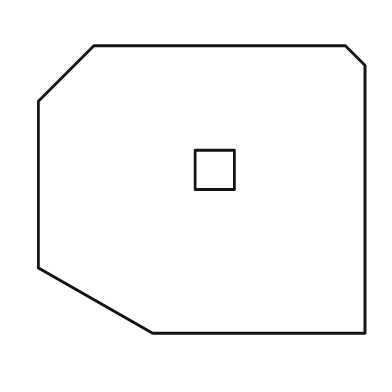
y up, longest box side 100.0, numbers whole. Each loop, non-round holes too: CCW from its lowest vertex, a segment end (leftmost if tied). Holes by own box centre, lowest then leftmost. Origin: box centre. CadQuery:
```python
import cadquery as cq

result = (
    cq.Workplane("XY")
    .moveTo(-15.0, -44.0)
    .lineTo(50.0, -44.0)
    .lineTo(50.0, 38.0)
    .lineTo(44.0, 44.0)
    .lineTo(-33.0, 44.0)
    .lineTo(-50.0, 27.0)
    .lineTo(-50.0, -24.0)
    .close()
    .moveTo(-2.0, 0.0)
    .lineTo(10.0, 0.0)
    .lineTo(10.0, 12.0)
    .lineTo(-2.0, 12.0)
    .close()
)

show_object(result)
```